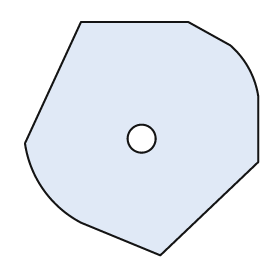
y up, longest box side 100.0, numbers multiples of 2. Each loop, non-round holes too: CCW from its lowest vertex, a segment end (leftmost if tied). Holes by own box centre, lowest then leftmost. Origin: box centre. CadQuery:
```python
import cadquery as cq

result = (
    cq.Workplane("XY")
    .moveTo(8.0, -50.0)
    .lineTo(50.0, -10.0)
    .lineTo(50.0, 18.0)
    .threePointArc((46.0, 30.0), (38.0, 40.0))
    .lineTo(20.0, 50.0)
    .lineTo(-26.0, 50.0)
    .lineTo(-50.0, -2.0)
    .threePointArc((-42.0, -22.0), (-26.0, -36.0))
    .close()
    .moveTo(0.0, 0.0)
    .circle(6.0)
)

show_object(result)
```